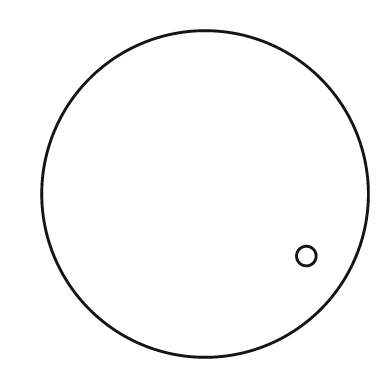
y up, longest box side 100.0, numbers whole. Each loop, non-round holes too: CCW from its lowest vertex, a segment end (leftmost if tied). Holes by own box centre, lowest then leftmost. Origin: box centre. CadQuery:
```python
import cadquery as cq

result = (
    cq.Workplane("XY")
    .moveTo(0.0, 0.0)
    .circle(50.0)
    .moveTo(31.0, -19.0)
    .circle(3.0)
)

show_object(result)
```